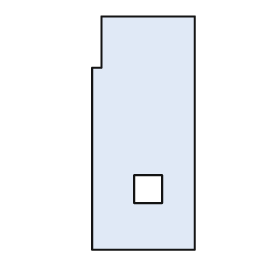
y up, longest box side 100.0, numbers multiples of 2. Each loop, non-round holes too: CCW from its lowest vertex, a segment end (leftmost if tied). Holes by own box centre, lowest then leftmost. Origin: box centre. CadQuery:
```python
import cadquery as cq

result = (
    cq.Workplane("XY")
    .moveTo(-22.0, -50.0)
    .lineTo(22.0, -50.0)
    .lineTo(22.0, 50.0)
    .lineTo(-18.0, 50.0)
    .lineTo(-18.0, 28.0)
    .lineTo(-22.0, 28.0)
    .close()
    .moveTo(-4.0, -30.0)
    .lineTo(8.0, -30.0)
    .lineTo(8.0, -18.0)
    .lineTo(-4.0, -18.0)
    .close()
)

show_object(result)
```